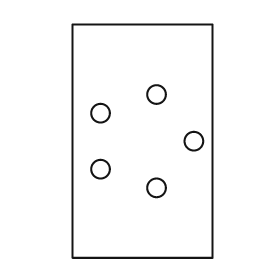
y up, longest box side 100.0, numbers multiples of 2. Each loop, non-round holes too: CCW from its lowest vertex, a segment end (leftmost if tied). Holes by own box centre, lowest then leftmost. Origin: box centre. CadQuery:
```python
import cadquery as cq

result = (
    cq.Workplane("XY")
    .moveTo(-30.0, -50.0)
    .lineTo(30.0, -50.0)
    .lineTo(30.0, 50.0)
    .lineTo(-30.0, 50.0)
    .close()
    .moveTo(6.0, -20.0)
    .circle(4.0)
    .moveTo(-18.0, -12.0)
    .circle(4.0)
    .moveTo(22.0, 0.0)
    .circle(4.0)
    .moveTo(-18.0, 12.0)
    .circle(4.0)
    .moveTo(6.0, 20.0)
    .circle(4.0)
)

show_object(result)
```